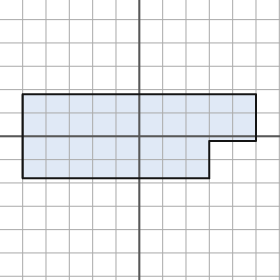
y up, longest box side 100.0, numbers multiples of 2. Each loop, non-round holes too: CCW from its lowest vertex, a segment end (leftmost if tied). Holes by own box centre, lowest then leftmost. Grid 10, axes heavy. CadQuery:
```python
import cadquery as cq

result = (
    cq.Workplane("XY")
    .moveTo(-50.0, -18.0)
    .lineTo(30.0, -18.0)
    .lineTo(30.0, -2.0)
    .lineTo(50.0, -2.0)
    .lineTo(50.0, 18.0)
    .lineTo(-50.0, 18.0)
    .close()
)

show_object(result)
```